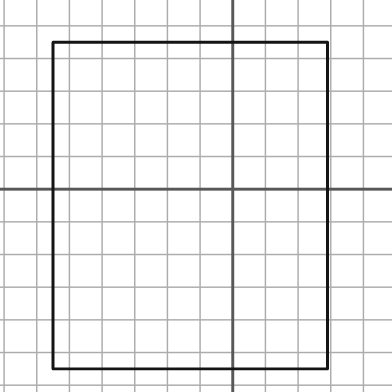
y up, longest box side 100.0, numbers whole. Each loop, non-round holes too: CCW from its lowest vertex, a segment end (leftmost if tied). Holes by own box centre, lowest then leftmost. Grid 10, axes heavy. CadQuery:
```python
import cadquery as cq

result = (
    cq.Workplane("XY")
    .moveTo(-55.0, -55.0)
    .lineTo(29.0, -55.0)
    .lineTo(29.0, 45.0)
    .lineTo(-55.0, 45.0)
    .close()
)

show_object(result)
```